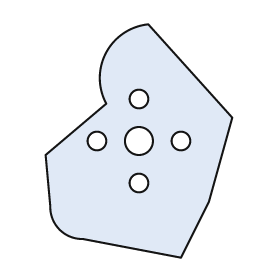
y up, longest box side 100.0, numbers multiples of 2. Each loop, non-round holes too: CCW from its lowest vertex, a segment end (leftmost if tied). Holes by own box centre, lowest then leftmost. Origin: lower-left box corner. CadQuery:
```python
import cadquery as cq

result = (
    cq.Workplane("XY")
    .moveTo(58.0, 0.0)
    .lineTo(70.0, 24.0)
    .lineTo(80.0, 60.0)
    .lineTo(44.0, 100.0)
    .threePointArc((26.0, 88.0), (26.0, 66.0))
    .lineTo(0.0, 44.0)
    .lineTo(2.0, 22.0)
    .threePointArc((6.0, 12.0), (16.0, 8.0))
    .close()
    .moveTo(40.0, 32.0)
    .circle(4.0)
    .moveTo(22.0, 50.0)
    .circle(4.0)
    .moveTo(40.0, 50.0)
    .circle(6.0)
    .moveTo(58.0, 50.0)
    .circle(4.0)
    .moveTo(40.0, 68.0)
    .circle(4.0)
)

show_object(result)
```